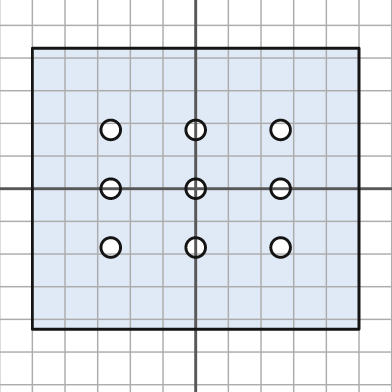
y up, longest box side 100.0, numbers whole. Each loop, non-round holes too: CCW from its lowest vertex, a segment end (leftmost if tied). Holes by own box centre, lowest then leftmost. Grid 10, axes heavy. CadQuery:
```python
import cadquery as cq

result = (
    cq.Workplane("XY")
    .moveTo(-50.0, -43.0)
    .lineTo(50.0, -43.0)
    .lineTo(50.0, 43.0)
    .lineTo(-50.0, 43.0)
    .close()
    .moveTo(-26.0, -18.0)
    .circle(3.0)
    .moveTo(0.0, -18.0)
    .circle(3.0)
    .moveTo(26.0, -18.0)
    .circle(3.0)
    .moveTo(-26.0, 0.0)
    .circle(3.0)
    .moveTo(0.0, 0.0)
    .circle(3.0)
    .moveTo(26.0, 0.0)
    .circle(3.0)
    .moveTo(-26.0, 18.0)
    .circle(3.0)
    .moveTo(0.0, 18.0)
    .circle(3.0)
    .moveTo(26.0, 18.0)
    .circle(3.0)
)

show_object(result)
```